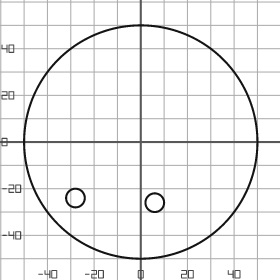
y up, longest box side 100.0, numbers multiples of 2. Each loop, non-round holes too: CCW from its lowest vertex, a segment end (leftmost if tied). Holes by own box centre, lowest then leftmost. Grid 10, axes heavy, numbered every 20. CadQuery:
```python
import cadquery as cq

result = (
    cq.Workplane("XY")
    .moveTo(0.0, 0.0)
    .circle(50.0)
    .moveTo(6.0, -26.0)
    .circle(4.0)
    .moveTo(-28.0, -24.0)
    .circle(4.0)
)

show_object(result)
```